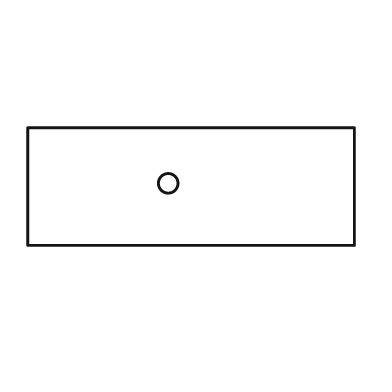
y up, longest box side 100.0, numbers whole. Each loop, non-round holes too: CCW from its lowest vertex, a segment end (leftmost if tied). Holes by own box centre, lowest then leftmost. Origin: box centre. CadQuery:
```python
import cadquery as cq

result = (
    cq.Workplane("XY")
    .moveTo(-50.0, -18.0)
    .lineTo(50.0, -18.0)
    .lineTo(50.0, 18.0)
    .lineTo(-50.0, 18.0)
    .close()
    .moveTo(-7.0, 1.0)
    .circle(3.0)
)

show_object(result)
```